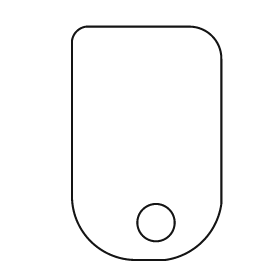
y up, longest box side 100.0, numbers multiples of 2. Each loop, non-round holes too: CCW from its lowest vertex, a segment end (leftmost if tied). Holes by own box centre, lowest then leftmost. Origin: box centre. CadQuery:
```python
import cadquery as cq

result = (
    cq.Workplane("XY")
    .moveTo(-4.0, -50.0)
    .lineTo(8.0, -50.0)
    .threePointArc((24.0, -42.0), (32.0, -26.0))
    .lineTo(32.0, 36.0)
    .threePointArc((28.0, 46.0), (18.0, 50.0))
    .lineTo(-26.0, 50.0)
    .threePointArc((-30.0, 48.0), (-32.0, 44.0))
    .lineTo(-32.0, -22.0)
    .threePointArc((-24.0, -42.0), (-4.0, -50.0))
    .close()
    .moveTo(4.0, -34.0)
    .circle(8.0)
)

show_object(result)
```